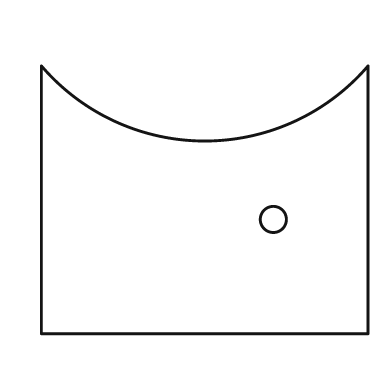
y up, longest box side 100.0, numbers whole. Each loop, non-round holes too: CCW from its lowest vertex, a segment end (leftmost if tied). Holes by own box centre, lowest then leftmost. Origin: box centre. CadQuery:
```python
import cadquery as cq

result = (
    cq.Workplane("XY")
    .moveTo(-50.0, -41.0)
    .lineTo(50.0, -41.0)
    .lineTo(50.0, 41.0)
    .threePointArc((0.0, 18.0), (-50.0, 41.0))
    .close()
    .moveTo(21.0, -6.0)
    .circle(4.0)
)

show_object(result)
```